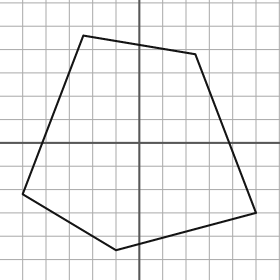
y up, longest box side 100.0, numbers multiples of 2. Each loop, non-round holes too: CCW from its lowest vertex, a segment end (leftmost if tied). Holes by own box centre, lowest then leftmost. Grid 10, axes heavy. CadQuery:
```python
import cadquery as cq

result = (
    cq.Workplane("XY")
    .moveTo(-10.0, -46.0)
    .lineTo(50.0, -30.0)
    .lineTo(24.0, 38.0)
    .lineTo(-24.0, 46.0)
    .lineTo(-50.0, -22.0)
    .close()
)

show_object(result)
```